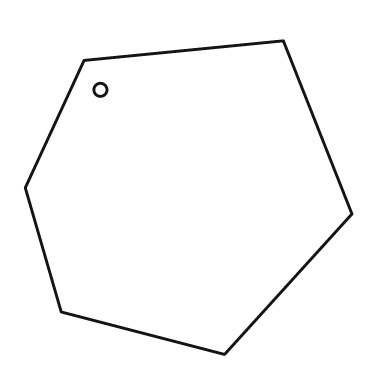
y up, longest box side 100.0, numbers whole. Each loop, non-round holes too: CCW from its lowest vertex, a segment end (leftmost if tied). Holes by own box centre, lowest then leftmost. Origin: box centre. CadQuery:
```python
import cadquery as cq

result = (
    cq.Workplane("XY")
    .moveTo(11.0, -48.0)
    .lineTo(50.0, -5.0)
    .lineTo(29.0, 48.0)
    .lineTo(-32.0, 42.0)
    .lineTo(-50.0, 3.0)
    .lineTo(-39.0, -35.0)
    .close()
    .moveTo(-27.0, 33.0)
    .circle(2.0)
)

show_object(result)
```